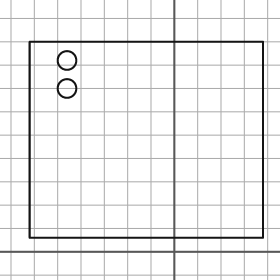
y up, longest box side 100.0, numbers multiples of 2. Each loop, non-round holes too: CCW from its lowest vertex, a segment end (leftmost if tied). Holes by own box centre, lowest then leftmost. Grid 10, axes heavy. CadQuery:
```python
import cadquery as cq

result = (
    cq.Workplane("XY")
    .moveTo(-62.0, 6.0)
    .lineTo(38.0, 6.0)
    .lineTo(38.0, 90.0)
    .lineTo(-62.0, 90.0)
    .close()
    .moveTo(-46.0, 70.0)
    .circle(4.0)
    .moveTo(-46.0, 82.0)
    .circle(4.0)
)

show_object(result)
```